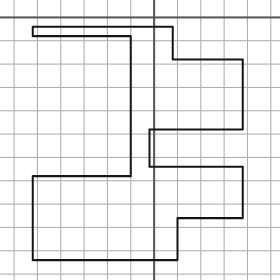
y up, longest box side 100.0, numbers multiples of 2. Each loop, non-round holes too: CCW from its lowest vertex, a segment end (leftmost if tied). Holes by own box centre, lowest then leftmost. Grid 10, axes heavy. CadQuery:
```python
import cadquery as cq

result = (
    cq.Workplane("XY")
    .moveTo(-52.0, -104.0)
    .lineTo(10.0, -104.0)
    .lineTo(10.0, -86.0)
    .lineTo(38.0, -86.0)
    .lineTo(38.0, -64.0)
    .lineTo(-2.0, -64.0)
    .lineTo(-2.0, -48.0)
    .lineTo(38.0, -48.0)
    .lineTo(38.0, -18.0)
    .lineTo(8.0, -18.0)
    .lineTo(8.0, -4.0)
    .lineTo(-52.0, -4.0)
    .lineTo(-52.0, -8.0)
    .lineTo(-10.0, -8.0)
    .lineTo(-10.0, -68.0)
    .lineTo(-52.0, -68.0)
    .close()
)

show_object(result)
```